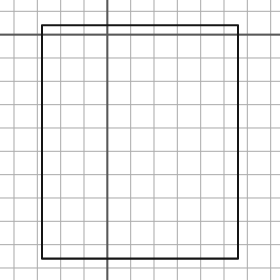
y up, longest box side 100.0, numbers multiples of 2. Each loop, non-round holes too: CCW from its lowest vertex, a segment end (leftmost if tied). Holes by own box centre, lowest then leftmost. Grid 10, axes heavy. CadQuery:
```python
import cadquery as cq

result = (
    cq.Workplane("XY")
    .moveTo(-28.0, -96.0)
    .lineTo(56.0, -96.0)
    .lineTo(56.0, 4.0)
    .lineTo(-28.0, 4.0)
    .close()
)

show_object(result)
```